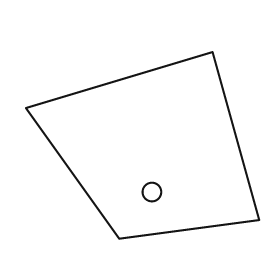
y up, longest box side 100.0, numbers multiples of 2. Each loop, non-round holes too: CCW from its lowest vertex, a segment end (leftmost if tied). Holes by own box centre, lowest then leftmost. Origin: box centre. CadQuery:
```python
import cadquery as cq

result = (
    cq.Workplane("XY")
    .moveTo(-10.0, -40.0)
    .lineTo(50.0, -32.0)
    .lineTo(30.0, 40.0)
    .lineTo(-50.0, 16.0)
    .close()
    .moveTo(4.0, -20.0)
    .circle(4.0)
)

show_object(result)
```